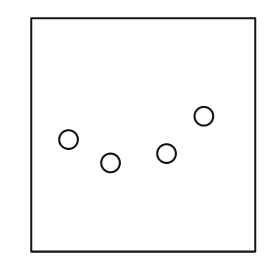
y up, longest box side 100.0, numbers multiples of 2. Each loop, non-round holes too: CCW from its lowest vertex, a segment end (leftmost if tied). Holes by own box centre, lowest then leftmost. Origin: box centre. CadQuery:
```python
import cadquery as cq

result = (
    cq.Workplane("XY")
    .moveTo(-48.0, -50.0)
    .lineTo(48.0, -50.0)
    .lineTo(48.0, 50.0)
    .lineTo(-48.0, 50.0)
    .close()
    .moveTo(-14.0, -12.0)
    .circle(4.0)
    .moveTo(10.0, -8.0)
    .circle(4.0)
    .moveTo(-32.0, -2.0)
    .circle(4.0)
    .moveTo(26.0, 8.0)
    .circle(4.0)
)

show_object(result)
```